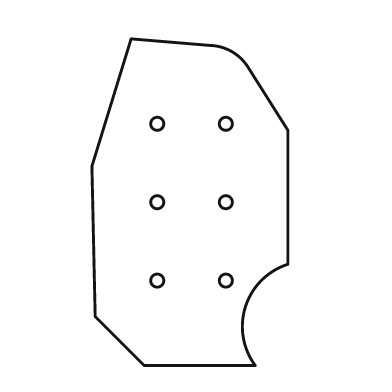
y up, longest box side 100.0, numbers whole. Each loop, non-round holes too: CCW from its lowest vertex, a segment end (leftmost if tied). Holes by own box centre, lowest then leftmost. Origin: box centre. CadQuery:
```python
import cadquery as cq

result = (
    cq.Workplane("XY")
    .moveTo(-14.0, -50.0)
    .lineTo(20.0, -50.0)
    .threePointArc((17.0, -32.0), (30.0, -19.0))
    .lineTo(30.0, 22.0)
    .lineTo(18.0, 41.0)
    .threePointArc((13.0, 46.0), (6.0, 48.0))
    .lineTo(-18.0, 50.0)
    .lineTo(-30.0, 11.0)
    .lineTo(-29.0, -35.0)
    .close()
    .moveTo(-10.0, -24.0)
    .circle(2.0)
    .moveTo(11.0, -24.0)
    .circle(2.0)
    .moveTo(-10.0, 0.0)
    .circle(2.0)
    .moveTo(11.0, 0.0)
    .circle(2.0)
    .moveTo(-10.0, 24.0)
    .circle(2.0)
    .moveTo(11.0, 24.0)
    .circle(2.0)
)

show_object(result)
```